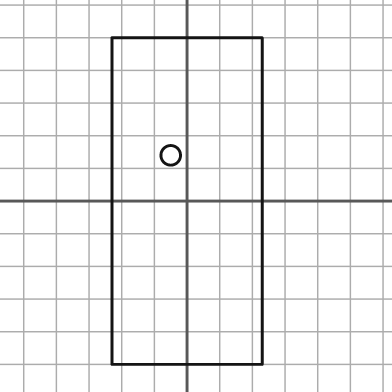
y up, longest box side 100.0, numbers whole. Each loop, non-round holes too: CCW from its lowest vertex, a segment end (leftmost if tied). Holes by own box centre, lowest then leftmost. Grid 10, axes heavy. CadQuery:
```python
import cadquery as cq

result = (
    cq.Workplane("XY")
    .moveTo(-23.0, -50.0)
    .lineTo(23.0, -50.0)
    .lineTo(23.0, 50.0)
    .lineTo(-23.0, 50.0)
    .close()
    .moveTo(-5.0, 14.0)
    .circle(3.0)
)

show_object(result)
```